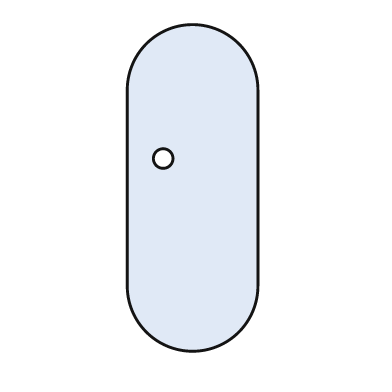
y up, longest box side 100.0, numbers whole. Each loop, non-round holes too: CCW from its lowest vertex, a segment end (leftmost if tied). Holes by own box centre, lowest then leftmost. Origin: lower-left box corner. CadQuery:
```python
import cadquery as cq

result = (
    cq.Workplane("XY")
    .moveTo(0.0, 20.0)
    .threePointArc((20.0, 0.0), (40.0, 20.0))
    .lineTo(40.0, 80.0)
    .threePointArc((20.0, 100.0), (0.0, 80.0))
    .close()
    .moveTo(11.0, 59.0)
    .circle(3.0)
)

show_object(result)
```